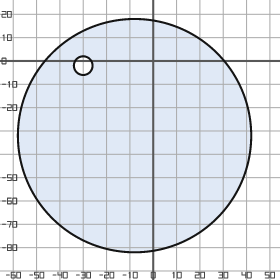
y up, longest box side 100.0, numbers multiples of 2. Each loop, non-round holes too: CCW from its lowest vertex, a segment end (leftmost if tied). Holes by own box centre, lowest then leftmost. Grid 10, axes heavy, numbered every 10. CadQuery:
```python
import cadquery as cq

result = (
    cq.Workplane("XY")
    .moveTo(-8.0, -32.0)
    .circle(50.0)
    .moveTo(-30.0, -2.0)
    .circle(4.0)
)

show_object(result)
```